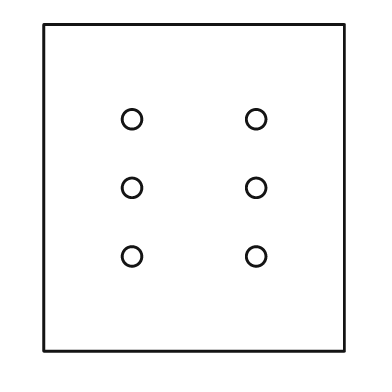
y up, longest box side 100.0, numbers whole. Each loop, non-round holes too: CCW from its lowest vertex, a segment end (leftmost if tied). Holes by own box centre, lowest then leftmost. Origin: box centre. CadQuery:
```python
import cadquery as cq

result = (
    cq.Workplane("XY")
    .moveTo(-46.0, -50.0)
    .lineTo(46.0, -50.0)
    .lineTo(46.0, 50.0)
    .lineTo(-46.0, 50.0)
    .close()
    .moveTo(-19.0, -21.0)
    .circle(3.0)
    .moveTo(19.0, -21.0)
    .circle(3.0)
    .moveTo(-19.0, 0.0)
    .circle(3.0)
    .moveTo(19.0, 0.0)
    .circle(3.0)
    .moveTo(-19.0, 21.0)
    .circle(3.0)
    .moveTo(19.0, 21.0)
    .circle(3.0)
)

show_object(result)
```